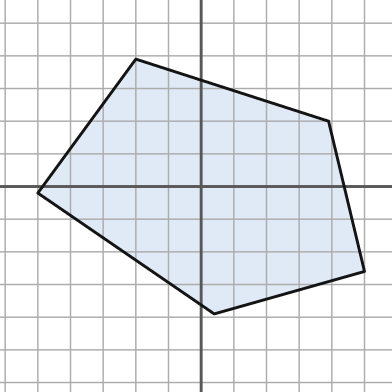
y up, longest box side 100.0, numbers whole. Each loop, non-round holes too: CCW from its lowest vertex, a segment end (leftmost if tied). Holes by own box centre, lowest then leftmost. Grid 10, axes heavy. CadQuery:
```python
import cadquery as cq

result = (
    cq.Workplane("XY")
    .moveTo(4.0, -39.0)
    .lineTo(50.0, -26.0)
    .lineTo(39.0, 20.0)
    .lineTo(-20.0, 39.0)
    .lineTo(-50.0, -2.0)
    .close()
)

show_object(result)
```